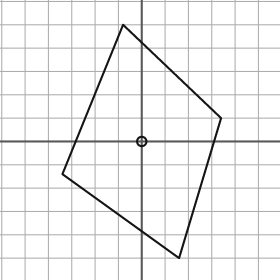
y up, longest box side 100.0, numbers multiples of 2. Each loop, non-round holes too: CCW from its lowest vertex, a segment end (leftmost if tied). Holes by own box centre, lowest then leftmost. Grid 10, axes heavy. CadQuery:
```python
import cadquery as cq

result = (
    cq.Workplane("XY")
    .moveTo(16.0, -50.0)
    .lineTo(34.0, 10.0)
    .lineTo(-8.0, 50.0)
    .lineTo(-34.0, -14.0)
    .close()
    .moveTo(0.0, 0.0)
    .circle(2.0)
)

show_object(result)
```